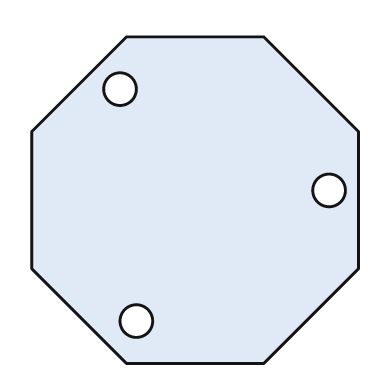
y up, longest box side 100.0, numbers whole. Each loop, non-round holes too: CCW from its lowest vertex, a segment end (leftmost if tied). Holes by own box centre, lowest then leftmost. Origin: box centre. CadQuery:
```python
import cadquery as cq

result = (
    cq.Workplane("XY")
    .moveTo(-21.0, -50.0)
    .lineTo(21.0, -50.0)
    .lineTo(50.0, -21.0)
    .lineTo(50.0, 21.0)
    .lineTo(21.0, 50.0)
    .lineTo(-21.0, 50.0)
    .lineTo(-50.0, 21.0)
    .lineTo(-50.0, -21.0)
    .close()
    .moveTo(-18.0, -37.0)
    .circle(5.0)
    .moveTo(41.0, 3.0)
    .circle(5.0)
    .moveTo(-23.0, 34.0)
    .circle(5.0)
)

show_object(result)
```